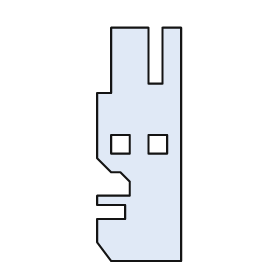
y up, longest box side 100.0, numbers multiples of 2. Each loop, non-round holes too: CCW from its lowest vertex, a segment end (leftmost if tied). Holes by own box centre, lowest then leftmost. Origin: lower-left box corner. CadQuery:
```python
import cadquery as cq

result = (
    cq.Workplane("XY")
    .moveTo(6.0, 0.0)
    .lineTo(36.0, 0.0)
    .lineTo(36.0, 100.0)
    .lineTo(28.0, 100.0)
    .lineTo(28.0, 76.0)
    .lineTo(22.0, 76.0)
    .lineTo(22.0, 100.0)
    .lineTo(6.0, 100.0)
    .lineTo(6.0, 72.0)
    .lineTo(0.0, 72.0)
    .lineTo(0.0, 44.0)
    .lineTo(6.0, 38.0)
    .lineTo(10.0, 38.0)
    .lineTo(14.0, 34.0)
    .lineTo(14.0, 28.0)
    .lineTo(0.0, 28.0)
    .lineTo(0.0, 24.0)
    .lineTo(12.0, 24.0)
    .lineTo(12.0, 18.0)
    .lineTo(0.0, 18.0)
    .lineTo(0.0, 8.0)
    .close()
    .moveTo(6.0, 46.0)
    .lineTo(14.0, 46.0)
    .lineTo(14.0, 54.0)
    .lineTo(6.0, 54.0)
    .close()
    .moveTo(22.0, 46.0)
    .lineTo(30.0, 46.0)
    .lineTo(30.0, 54.0)
    .lineTo(22.0, 54.0)
    .close()
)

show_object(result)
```